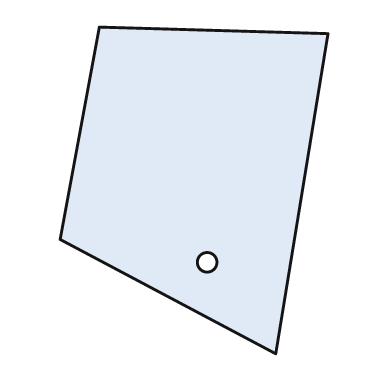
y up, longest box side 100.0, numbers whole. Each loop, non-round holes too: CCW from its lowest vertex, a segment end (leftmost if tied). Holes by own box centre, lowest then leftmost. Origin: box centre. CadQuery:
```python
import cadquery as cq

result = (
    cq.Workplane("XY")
    .moveTo(25.0, -50.0)
    .lineTo(41.0, 48.0)
    .lineTo(-29.0, 50.0)
    .lineTo(-41.0, -15.0)
    .close()
    .moveTo(4.0, -22.0)
    .circle(3.0)
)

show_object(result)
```